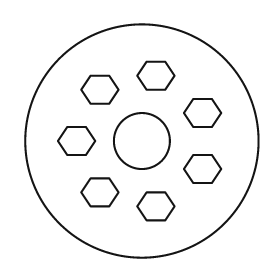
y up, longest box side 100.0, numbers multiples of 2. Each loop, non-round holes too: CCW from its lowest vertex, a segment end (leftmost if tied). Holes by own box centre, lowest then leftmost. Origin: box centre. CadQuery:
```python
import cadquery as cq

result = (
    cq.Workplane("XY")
    .moveTo(0.0, 0.0)
    .circle(50.0)
    .moveTo(2.0, -34.0)
    .lineTo(10.0, -34.0)
    .lineTo(14.0, -28.0)
    .lineTo(10.0, -22.0)
    .lineTo(2.0, -22.0)
    .lineTo(-2.0, -28.0)
    .close()
    .moveTo(-22.0, -28.0)
    .lineTo(-14.0, -28.0)
    .lineTo(-10.0, -22.0)
    .lineTo(-14.0, -16.0)
    .lineTo(-22.0, -16.0)
    .lineTo(-26.0, -22.0)
    .close()
    .moveTo(22.0, -18.0)
    .lineTo(30.0, -18.0)
    .lineTo(34.0, -12.0)
    .lineTo(30.0, -6.0)
    .lineTo(22.0, -6.0)
    .lineTo(18.0, -12.0)
    .close()
    .moveTo(-32.0, -6.0)
    .lineTo(-24.0, -6.0)
    .lineTo(-20.0, 0.0)
    .lineTo(-24.0, 6.0)
    .lineTo(-32.0, 6.0)
    .lineTo(-36.0, 0.0)
    .close()
    .moveTo(0.0, 0.0)
    .circle(12.0)
    .moveTo(22.0, 6.0)
    .lineTo(30.0, 6.0)
    .lineTo(34.0, 12.0)
    .lineTo(30.0, 18.0)
    .lineTo(22.0, 18.0)
    .lineTo(18.0, 12.0)
    .close()
    .moveTo(-22.0, 16.0)
    .lineTo(-14.0, 16.0)
    .lineTo(-10.0, 22.0)
    .lineTo(-14.0, 28.0)
    .lineTo(-22.0, 28.0)
    .lineTo(-26.0, 22.0)
    .close()
    .moveTo(2.0, 22.0)
    .lineTo(10.0, 22.0)
    .lineTo(14.0, 28.0)
    .lineTo(10.0, 34.0)
    .lineTo(2.0, 34.0)
    .lineTo(-2.0, 28.0)
    .close()
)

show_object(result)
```